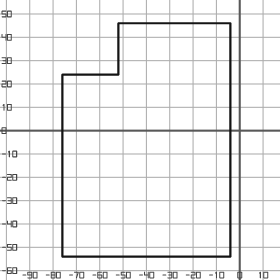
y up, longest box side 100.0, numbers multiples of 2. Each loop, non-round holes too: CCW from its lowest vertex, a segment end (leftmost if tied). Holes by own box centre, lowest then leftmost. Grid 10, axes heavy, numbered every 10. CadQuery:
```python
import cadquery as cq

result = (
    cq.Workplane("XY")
    .moveTo(-76.0, -54.0)
    .lineTo(-4.0, -54.0)
    .lineTo(-4.0, 46.0)
    .lineTo(-52.0, 46.0)
    .lineTo(-52.0, 24.0)
    .lineTo(-76.0, 24.0)
    .close()
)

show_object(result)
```